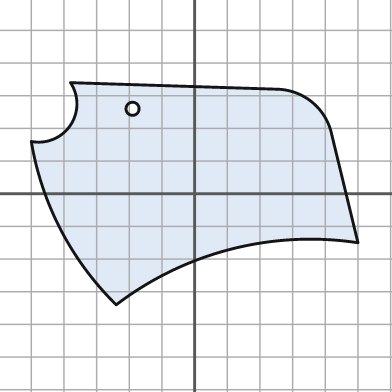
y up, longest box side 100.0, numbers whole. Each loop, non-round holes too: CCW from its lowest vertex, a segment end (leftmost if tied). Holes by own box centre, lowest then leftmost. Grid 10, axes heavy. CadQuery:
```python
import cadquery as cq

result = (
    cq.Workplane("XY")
    .moveTo(-24.0, -34.0)
    .threePointArc((11.0, -17.0), (50.0, -15.0))
    .lineTo(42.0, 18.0)
    .threePointArc((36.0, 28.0), (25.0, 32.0))
    .lineTo(-38.0, 34.0)
    .threePointArc((-38.0, 21.0), (-50.0, 16.0))
    .threePointArc((-41.0, -11.0), (-24.0, -34.0))
    .close()
    .moveTo(-19.0, 26.0)
    .circle(2.0)
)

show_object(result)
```